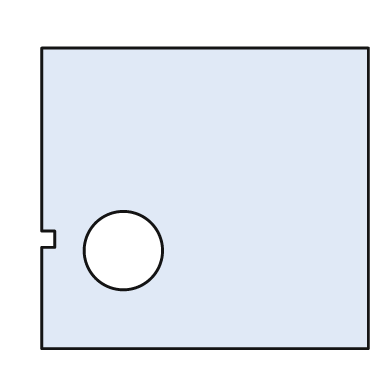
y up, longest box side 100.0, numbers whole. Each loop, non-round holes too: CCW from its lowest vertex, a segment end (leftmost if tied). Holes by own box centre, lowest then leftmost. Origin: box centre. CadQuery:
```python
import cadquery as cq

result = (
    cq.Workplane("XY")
    .moveTo(-50.0, -46.0)
    .lineTo(50.0, -46.0)
    .lineTo(50.0, 46.0)
    .lineTo(-50.0, 46.0)
    .lineTo(-50.0, -10.0)
    .lineTo(-46.0, -10.0)
    .lineTo(-46.0, -15.0)
    .lineTo(-50.0, -15.0)
    .close()
    .moveTo(-25.0, -16.0)
    .circle(12.0)
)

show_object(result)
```